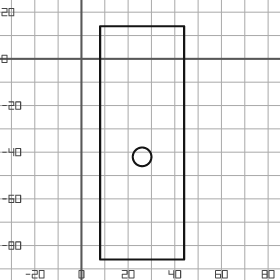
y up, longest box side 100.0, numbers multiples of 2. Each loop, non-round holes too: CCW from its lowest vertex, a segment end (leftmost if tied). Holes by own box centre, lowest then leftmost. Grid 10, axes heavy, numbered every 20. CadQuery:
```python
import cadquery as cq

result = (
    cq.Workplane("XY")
    .moveTo(8.0, -86.0)
    .lineTo(44.0, -86.0)
    .lineTo(44.0, 14.0)
    .lineTo(8.0, 14.0)
    .close()
    .moveTo(26.0, -42.0)
    .circle(4.0)
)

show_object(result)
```